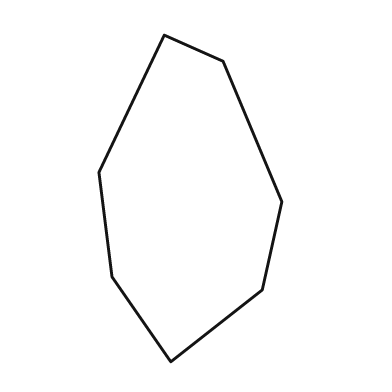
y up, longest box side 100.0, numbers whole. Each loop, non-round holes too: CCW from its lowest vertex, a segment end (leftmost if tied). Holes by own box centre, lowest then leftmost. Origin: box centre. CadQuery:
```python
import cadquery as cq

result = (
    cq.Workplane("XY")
    .moveTo(-6.0, -50.0)
    .lineTo(22.0, -28.0)
    .lineTo(28.0, -1.0)
    .lineTo(10.0, 42.0)
    .lineTo(-8.0, 50.0)
    .lineTo(-28.0, 8.0)
    .lineTo(-24.0, -24.0)
    .close()
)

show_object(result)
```